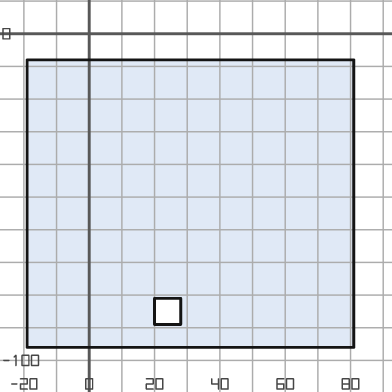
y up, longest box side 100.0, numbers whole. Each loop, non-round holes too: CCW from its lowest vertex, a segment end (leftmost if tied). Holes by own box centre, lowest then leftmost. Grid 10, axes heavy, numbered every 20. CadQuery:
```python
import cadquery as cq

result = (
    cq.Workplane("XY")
    .moveTo(-19.0, -96.0)
    .lineTo(81.0, -96.0)
    .lineTo(81.0, -8.0)
    .lineTo(-19.0, -8.0)
    .close()
    .moveTo(20.0, -89.0)
    .lineTo(28.0, -89.0)
    .lineTo(28.0, -81.0)
    .lineTo(20.0, -81.0)
    .close()
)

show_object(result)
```